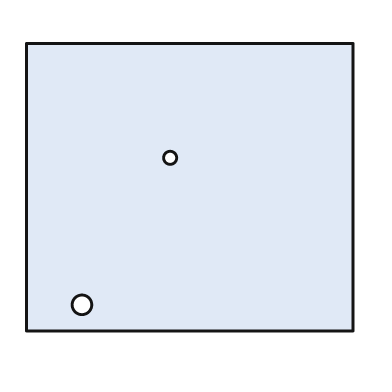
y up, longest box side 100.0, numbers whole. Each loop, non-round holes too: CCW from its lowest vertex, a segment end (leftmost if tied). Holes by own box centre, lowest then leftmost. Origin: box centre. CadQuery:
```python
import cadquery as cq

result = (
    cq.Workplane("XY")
    .moveTo(-50.0, -44.0)
    .lineTo(50.0, -44.0)
    .lineTo(50.0, 44.0)
    .lineTo(-50.0, 44.0)
    .close()
    .moveTo(-33.0, -36.0)
    .circle(3.0)
    .moveTo(-6.0, 9.0)
    .circle(2.0)
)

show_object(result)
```